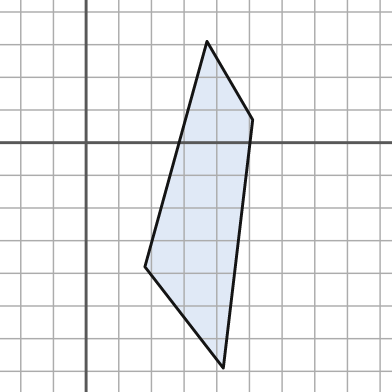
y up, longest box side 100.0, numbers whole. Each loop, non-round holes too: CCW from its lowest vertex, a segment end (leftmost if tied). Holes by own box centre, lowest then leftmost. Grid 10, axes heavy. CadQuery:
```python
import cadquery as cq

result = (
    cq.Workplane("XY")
    .moveTo(42.0, -69.0)
    .lineTo(51.0, 7.0)
    .lineTo(37.0, 31.0)
    .lineTo(18.0, -38.0)
    .close()
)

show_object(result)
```